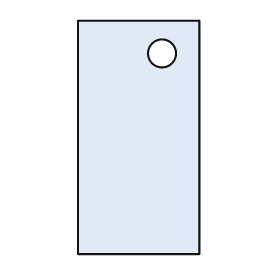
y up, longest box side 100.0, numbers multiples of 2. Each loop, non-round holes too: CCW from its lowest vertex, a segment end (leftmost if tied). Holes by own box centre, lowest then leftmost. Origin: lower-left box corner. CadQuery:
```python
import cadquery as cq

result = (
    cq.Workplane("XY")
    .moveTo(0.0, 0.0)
    .lineTo(52.0, 0.0)
    .lineTo(52.0, 100.0)
    .lineTo(0.0, 100.0)
    .close()
    .moveTo(36.0, 86.0)
    .circle(6.0)
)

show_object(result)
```